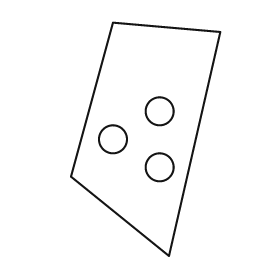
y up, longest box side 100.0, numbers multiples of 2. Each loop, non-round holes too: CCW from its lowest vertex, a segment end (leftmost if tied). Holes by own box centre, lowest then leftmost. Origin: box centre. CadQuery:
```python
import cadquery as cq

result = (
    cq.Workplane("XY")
    .moveTo(10.0, -50.0)
    .lineTo(32.0, 46.0)
    .lineTo(-14.0, 50.0)
    .lineTo(-32.0, -16.0)
    .close()
    .moveTo(6.0, -12.0)
    .circle(6.0)
    .moveTo(-14.0, 0.0)
    .circle(6.0)
    .moveTo(6.0, 12.0)
    .circle(6.0)
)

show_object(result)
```